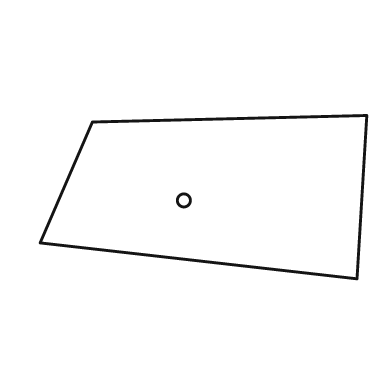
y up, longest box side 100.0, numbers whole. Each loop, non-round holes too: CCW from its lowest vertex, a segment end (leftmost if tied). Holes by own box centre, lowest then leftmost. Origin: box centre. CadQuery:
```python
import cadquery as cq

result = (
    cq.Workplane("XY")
    .moveTo(47.0, -25.0)
    .lineTo(50.0, 25.0)
    .lineTo(-34.0, 23.0)
    .lineTo(-50.0, -14.0)
    .close()
    .moveTo(-6.0, -1.0)
    .circle(2.0)
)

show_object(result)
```